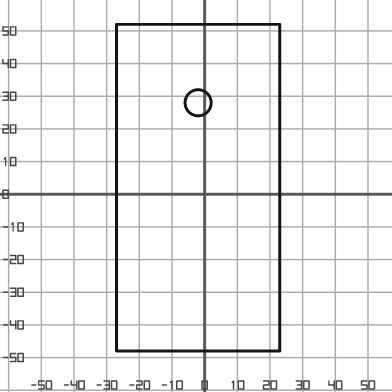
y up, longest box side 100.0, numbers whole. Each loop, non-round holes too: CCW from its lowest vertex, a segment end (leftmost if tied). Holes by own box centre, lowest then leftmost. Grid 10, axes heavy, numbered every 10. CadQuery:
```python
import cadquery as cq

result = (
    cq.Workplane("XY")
    .moveTo(-27.0, -48.0)
    .lineTo(23.0, -48.0)
    .lineTo(23.0, 52.0)
    .lineTo(-27.0, 52.0)
    .close()
    .moveTo(-2.0, 28.0)
    .circle(4.0)
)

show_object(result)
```